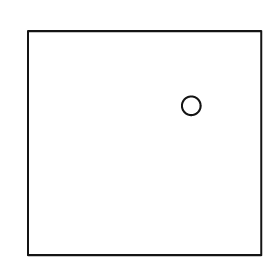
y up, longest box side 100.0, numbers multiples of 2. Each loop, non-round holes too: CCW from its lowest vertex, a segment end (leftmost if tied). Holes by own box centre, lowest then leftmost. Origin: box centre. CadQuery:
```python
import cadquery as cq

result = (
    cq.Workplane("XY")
    .moveTo(-50.0, -48.0)
    .lineTo(50.0, -48.0)
    .lineTo(50.0, 48.0)
    .lineTo(-50.0, 48.0)
    .close()
    .moveTo(20.0, 16.0)
    .circle(4.0)
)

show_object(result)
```